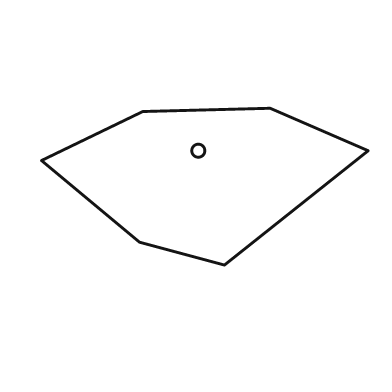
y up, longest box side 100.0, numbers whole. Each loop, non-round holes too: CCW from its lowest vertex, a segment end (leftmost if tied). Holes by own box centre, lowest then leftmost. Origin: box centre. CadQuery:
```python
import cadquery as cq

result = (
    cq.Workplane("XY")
    .moveTo(6.0, -24.0)
    .lineTo(50.0, 11.0)
    .lineTo(20.0, 24.0)
    .lineTo(-19.0, 23.0)
    .lineTo(-50.0, 8.0)
    .lineTo(-20.0, -17.0)
    .close()
    .moveTo(-2.0, 11.0)
    .circle(2.0)
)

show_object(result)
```